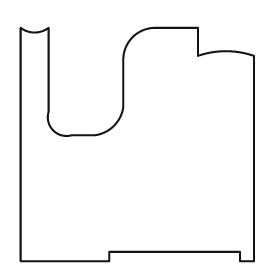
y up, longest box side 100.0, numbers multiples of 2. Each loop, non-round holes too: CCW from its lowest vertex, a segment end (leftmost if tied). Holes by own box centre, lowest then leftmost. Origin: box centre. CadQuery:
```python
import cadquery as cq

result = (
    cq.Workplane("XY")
    .moveTo(-50.0, -50.0)
    .lineTo(-12.0, -50.0)
    .lineTo(-12.0, -46.0)
    .lineTo(44.0, -46.0)
    .lineTo(44.0, -50.0)
    .lineTo(50.0, -50.0)
    .lineTo(50.0, 38.0)
    .threePointArc((38.0, 40.0), (26.0, 38.0))
    .lineTo(26.0, 50.0)
    .lineTo(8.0, 50.0)
    .threePointArc((-2.0, 46.0), (-6.0, 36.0))
    .lineTo(-6.0, 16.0)
    .threePointArc((-10.0, 8.0), (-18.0, 4.0))
    .lineTo(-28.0, 4.0)
    .threePointArc((-36.0, 6.0), (-38.0, 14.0))
    .lineTo(-38.0, 50.0)
    .threePointArc((-44.0, 48.0), (-50.0, 50.0))
    .close()
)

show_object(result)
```